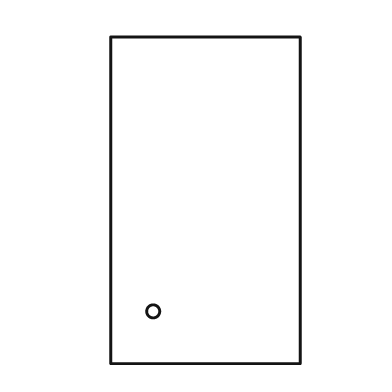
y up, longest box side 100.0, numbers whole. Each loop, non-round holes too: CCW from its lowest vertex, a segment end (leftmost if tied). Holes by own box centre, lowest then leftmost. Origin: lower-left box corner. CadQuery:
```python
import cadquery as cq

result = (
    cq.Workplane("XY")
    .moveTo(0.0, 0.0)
    .lineTo(58.0, 0.0)
    .lineTo(58.0, 100.0)
    .lineTo(0.0, 100.0)
    .close()
    .moveTo(13.0, 16.0)
    .circle(2.0)
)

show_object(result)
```